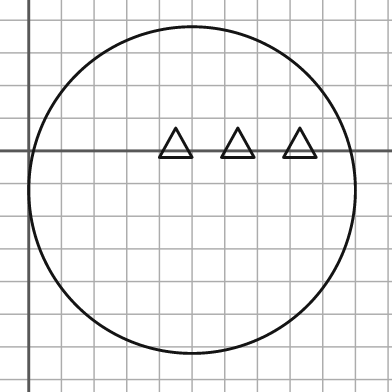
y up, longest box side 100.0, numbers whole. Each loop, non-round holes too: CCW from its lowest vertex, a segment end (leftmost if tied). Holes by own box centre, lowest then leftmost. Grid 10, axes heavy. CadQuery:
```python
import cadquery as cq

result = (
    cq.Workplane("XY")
    .moveTo(50.0, -12.0)
    .circle(50.0)
    .moveTo(40.0, -2.0)
    .lineTo(50.0, -2.0)
    .lineTo(45.0, 7.0)
    .close()
    .moveTo(59.0, -2.0)
    .lineTo(69.0, -2.0)
    .lineTo(64.0, 7.0)
    .close()
    .moveTo(78.0, -2.0)
    .lineTo(88.0, -2.0)
    .lineTo(83.0, 7.0)
    .close()
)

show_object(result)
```